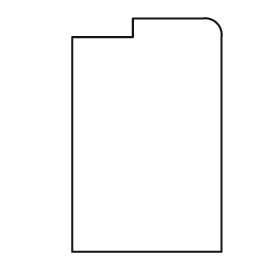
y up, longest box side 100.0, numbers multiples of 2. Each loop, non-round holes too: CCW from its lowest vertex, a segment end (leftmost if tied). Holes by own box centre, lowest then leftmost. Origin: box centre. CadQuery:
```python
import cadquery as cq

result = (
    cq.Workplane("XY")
    .moveTo(-32.0, -50.0)
    .lineTo(32.0, -50.0)
    .lineTo(32.0, 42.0)
    .threePointArc((30.0, 48.0), (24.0, 50.0))
    .lineTo(-6.0, 50.0)
    .lineTo(-6.0, 42.0)
    .lineTo(-32.0, 42.0)
    .close()
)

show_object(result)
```